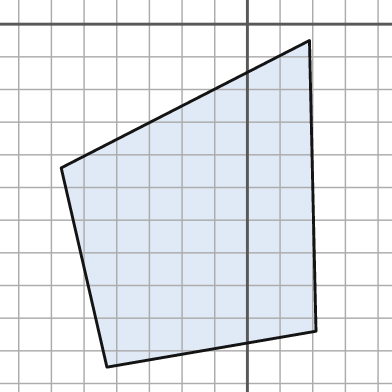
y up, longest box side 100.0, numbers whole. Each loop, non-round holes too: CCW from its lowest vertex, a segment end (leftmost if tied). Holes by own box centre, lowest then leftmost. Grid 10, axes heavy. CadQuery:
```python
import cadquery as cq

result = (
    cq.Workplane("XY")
    .moveTo(-43.0, -105.0)
    .lineTo(21.0, -94.0)
    .lineTo(19.0, -5.0)
    .lineTo(-57.0, -44.0)
    .close()
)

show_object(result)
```